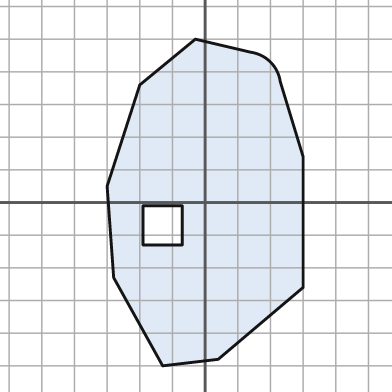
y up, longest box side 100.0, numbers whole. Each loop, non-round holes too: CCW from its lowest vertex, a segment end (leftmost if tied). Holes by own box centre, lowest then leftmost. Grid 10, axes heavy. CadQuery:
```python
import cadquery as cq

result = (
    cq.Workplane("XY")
    .moveTo(-13.0, -50.0)
    .lineTo(4.0, -48.0)
    .lineTo(30.0, -26.0)
    .lineTo(30.0, 14.0)
    .lineTo(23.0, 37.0)
    .threePointArc((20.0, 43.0), (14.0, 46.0))
    .lineTo(-3.0, 50.0)
    .lineTo(-20.0, 36.0)
    .lineTo(-30.0, 5.0)
    .lineTo(-28.0, -23.0)
    .close()
    .moveTo(-19.0, -13.0)
    .lineTo(-7.0, -13.0)
    .lineTo(-7.0, -1.0)
    .lineTo(-19.0, -1.0)
    .close()
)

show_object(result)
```